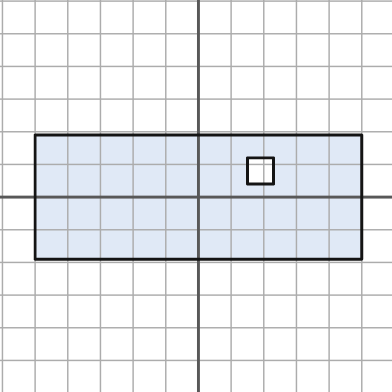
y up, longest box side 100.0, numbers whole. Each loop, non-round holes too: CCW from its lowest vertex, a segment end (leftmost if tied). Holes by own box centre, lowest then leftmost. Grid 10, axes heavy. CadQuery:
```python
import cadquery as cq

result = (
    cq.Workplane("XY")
    .moveTo(-50.0, -19.0)
    .lineTo(50.0, -19.0)
    .lineTo(50.0, 19.0)
    .lineTo(-50.0, 19.0)
    .close()
    .moveTo(15.0, 4.0)
    .lineTo(23.0, 4.0)
    .lineTo(23.0, 12.0)
    .lineTo(15.0, 12.0)
    .close()
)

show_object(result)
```